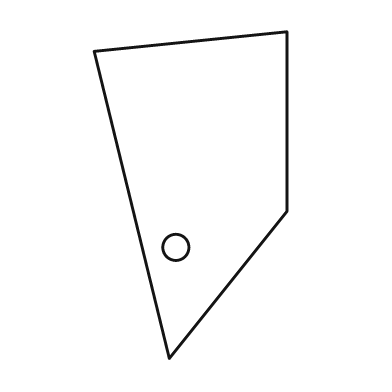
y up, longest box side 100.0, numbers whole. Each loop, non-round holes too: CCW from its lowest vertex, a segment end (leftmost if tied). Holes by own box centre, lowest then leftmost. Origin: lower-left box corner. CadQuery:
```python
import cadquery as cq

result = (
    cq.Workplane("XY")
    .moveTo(23.0, 0.0)
    .lineTo(59.0, 45.0)
    .lineTo(59.0, 100.0)
    .lineTo(0.0, 94.0)
    .close()
    .moveTo(25.0, 34.0)
    .circle(4.0)
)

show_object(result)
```